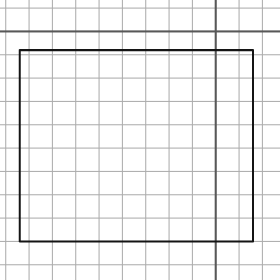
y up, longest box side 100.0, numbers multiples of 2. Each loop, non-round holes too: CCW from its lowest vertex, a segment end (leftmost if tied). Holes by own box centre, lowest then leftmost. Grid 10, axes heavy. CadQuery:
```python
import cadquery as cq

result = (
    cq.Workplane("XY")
    .moveTo(-84.0, -90.0)
    .lineTo(16.0, -90.0)
    .lineTo(16.0, -8.0)
    .lineTo(-84.0, -8.0)
    .close()
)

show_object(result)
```